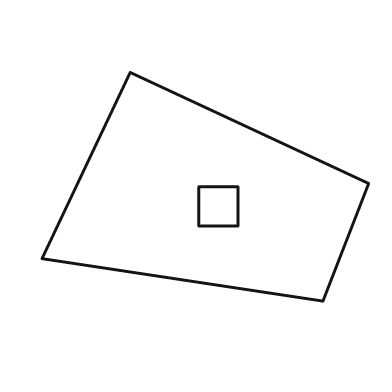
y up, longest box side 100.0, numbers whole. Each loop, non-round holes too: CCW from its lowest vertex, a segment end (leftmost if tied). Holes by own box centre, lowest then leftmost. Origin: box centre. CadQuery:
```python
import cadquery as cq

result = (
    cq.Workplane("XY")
    .moveTo(36.0, -35.0)
    .lineTo(50.0, 1.0)
    .lineTo(-23.0, 35.0)
    .lineTo(-50.0, -22.0)
    .close()
    .moveTo(-2.0, -12.0)
    .lineTo(10.0, -12.0)
    .lineTo(10.0, 0.0)
    .lineTo(-2.0, 0.0)
    .close()
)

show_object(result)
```